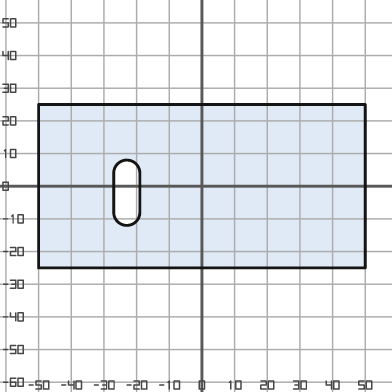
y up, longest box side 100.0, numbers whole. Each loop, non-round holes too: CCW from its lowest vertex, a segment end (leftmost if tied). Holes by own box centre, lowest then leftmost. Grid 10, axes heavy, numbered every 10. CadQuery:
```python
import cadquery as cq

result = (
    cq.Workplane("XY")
    .moveTo(-50.0, -25.0)
    .lineTo(50.0, -25.0)
    .lineTo(50.0, 25.0)
    .lineTo(-50.0, 25.0)
    .close()
    .moveTo(-27.0, -8.0)
    .threePointArc((-23.0, -12.0), (-19.0, -8.0))
    .lineTo(-19.0, 4.0)
    .threePointArc((-23.0, 8.0), (-27.0, 4.0))
    .close()
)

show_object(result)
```